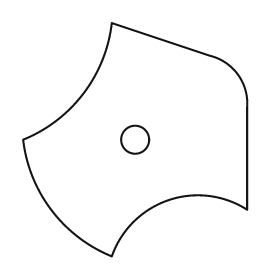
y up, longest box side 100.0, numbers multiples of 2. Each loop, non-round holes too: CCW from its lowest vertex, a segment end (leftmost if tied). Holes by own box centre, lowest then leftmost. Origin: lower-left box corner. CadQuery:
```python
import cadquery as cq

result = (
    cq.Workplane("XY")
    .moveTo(38.0, 0.0)
    .threePointArc((62.0, 24.0), (96.0, 20.0))
    .lineTo(96.0, 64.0)
    .threePointArc((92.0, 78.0), (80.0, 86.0))
    .lineTo(38.0, 100.0)
    .threePointArc((26.0, 70.0), (0.0, 50.0))
    .threePointArc((12.0, 20.0), (38.0, 0.0))
    .close()
    .moveTo(48.0, 50.0)
    .circle(6.0)
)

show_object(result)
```